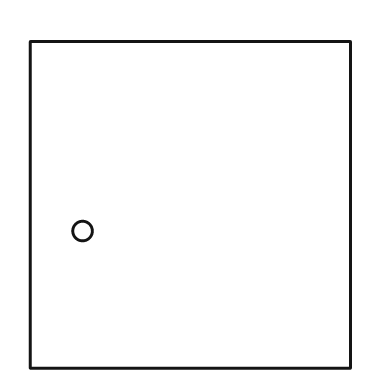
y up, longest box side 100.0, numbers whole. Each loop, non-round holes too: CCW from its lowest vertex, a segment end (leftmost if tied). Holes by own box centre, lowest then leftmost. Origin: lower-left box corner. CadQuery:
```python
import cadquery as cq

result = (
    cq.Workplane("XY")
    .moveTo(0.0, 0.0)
    .lineTo(98.0, 0.0)
    .lineTo(98.0, 100.0)
    .lineTo(0.0, 100.0)
    .close()
    .moveTo(16.0, 42.0)
    .circle(3.0)
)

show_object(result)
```